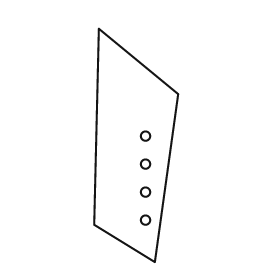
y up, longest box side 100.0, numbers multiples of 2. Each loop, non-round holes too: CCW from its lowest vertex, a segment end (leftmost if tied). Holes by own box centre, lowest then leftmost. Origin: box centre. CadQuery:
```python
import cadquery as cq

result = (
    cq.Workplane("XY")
    .moveTo(8.0, -50.0)
    .lineTo(18.0, 22.0)
    .lineTo(-16.0, 50.0)
    .lineTo(-18.0, -34.0)
    .close()
    .moveTo(4.0, -32.0)
    .circle(2.0)
    .moveTo(4.0, -20.0)
    .circle(2.0)
    .moveTo(4.0, -8.0)
    .circle(2.0)
    .moveTo(4.0, 4.0)
    .circle(2.0)
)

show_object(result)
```